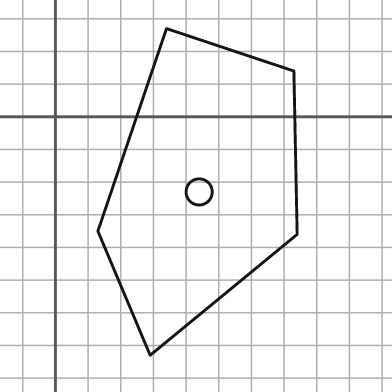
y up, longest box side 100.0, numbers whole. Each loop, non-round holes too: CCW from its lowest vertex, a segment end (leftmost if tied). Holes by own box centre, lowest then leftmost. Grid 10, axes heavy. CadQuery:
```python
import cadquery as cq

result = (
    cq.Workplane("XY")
    .moveTo(29.0, -73.0)
    .lineTo(74.0, -36.0)
    .lineTo(73.0, 14.0)
    .lineTo(34.0, 27.0)
    .lineTo(13.0, -35.0)
    .close()
    .moveTo(44.0, -23.0)
    .circle(4.0)
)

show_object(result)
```